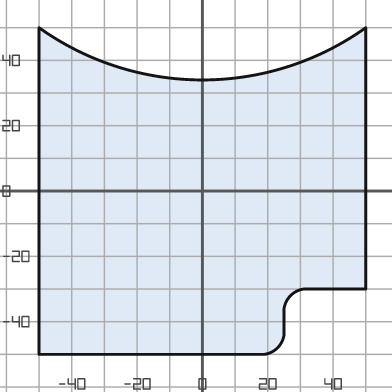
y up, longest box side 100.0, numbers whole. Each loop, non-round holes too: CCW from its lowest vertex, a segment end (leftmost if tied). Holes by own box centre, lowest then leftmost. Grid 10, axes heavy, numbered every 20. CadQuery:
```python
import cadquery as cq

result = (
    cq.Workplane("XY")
    .moveTo(-50.0, -50.0)
    .lineTo(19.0, -50.0)
    .threePointArc((23.0, -48.0), (25.0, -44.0))
    .lineTo(25.0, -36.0)
    .threePointArc((27.0, -32.0), (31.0, -30.0))
    .lineTo(50.0, -30.0)
    .lineTo(50.0, 50.0)
    .threePointArc((0.0, 34.0), (-50.0, 50.0))
    .close()
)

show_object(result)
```